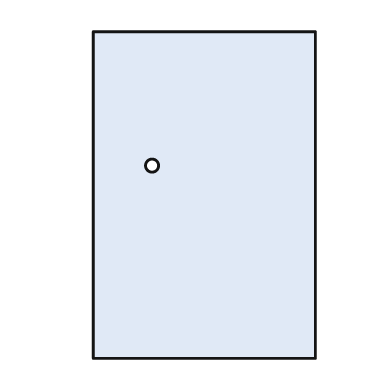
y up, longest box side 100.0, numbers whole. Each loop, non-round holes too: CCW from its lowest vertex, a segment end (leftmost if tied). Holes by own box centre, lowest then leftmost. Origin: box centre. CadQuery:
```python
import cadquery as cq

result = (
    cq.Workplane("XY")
    .moveTo(-34.0, -50.0)
    .lineTo(34.0, -50.0)
    .lineTo(34.0, 50.0)
    .lineTo(-34.0, 50.0)
    .close()
    .moveTo(-16.0, 9.0)
    .circle(2.0)
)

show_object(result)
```